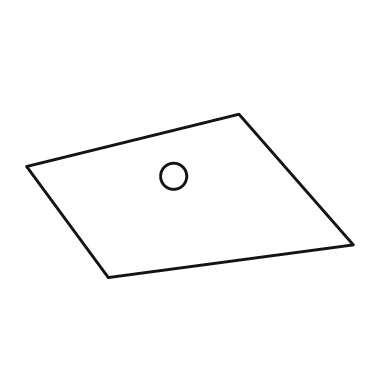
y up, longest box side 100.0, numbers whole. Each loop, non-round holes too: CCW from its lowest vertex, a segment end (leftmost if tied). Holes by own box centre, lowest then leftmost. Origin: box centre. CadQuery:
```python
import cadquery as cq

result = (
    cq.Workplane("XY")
    .moveTo(-25.0, -25.0)
    .lineTo(50.0, -15.0)
    .lineTo(15.0, 25.0)
    .lineTo(-50.0, 9.0)
    .close()
    .moveTo(-5.0, 6.0)
    .circle(4.0)
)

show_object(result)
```